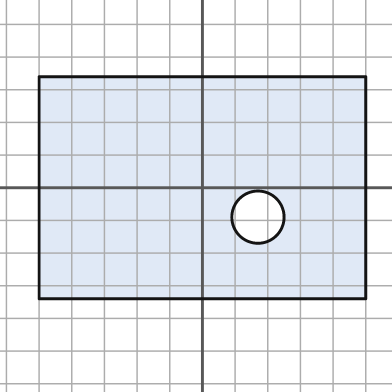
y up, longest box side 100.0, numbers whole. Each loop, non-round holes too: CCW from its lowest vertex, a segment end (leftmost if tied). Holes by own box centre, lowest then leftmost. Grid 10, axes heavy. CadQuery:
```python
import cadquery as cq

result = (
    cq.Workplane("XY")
    .moveTo(-50.0, -34.0)
    .lineTo(50.0, -34.0)
    .lineTo(50.0, 34.0)
    .lineTo(-50.0, 34.0)
    .close()
    .moveTo(17.0, -9.0)
    .circle(8.0)
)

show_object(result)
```